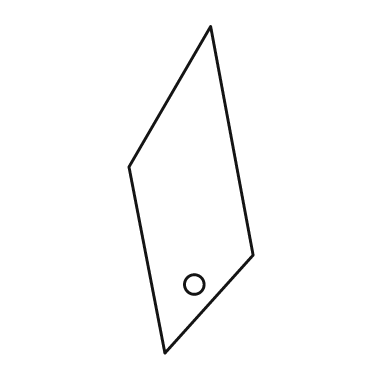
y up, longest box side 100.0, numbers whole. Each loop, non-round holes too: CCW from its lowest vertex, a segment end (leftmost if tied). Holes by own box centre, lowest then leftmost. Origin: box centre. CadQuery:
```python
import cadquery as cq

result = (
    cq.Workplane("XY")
    .moveTo(-8.0, -50.0)
    .lineTo(19.0, -20.0)
    .lineTo(6.0, 50.0)
    .lineTo(-19.0, 7.0)
    .close()
    .moveTo(1.0, -29.0)
    .circle(3.0)
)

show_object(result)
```